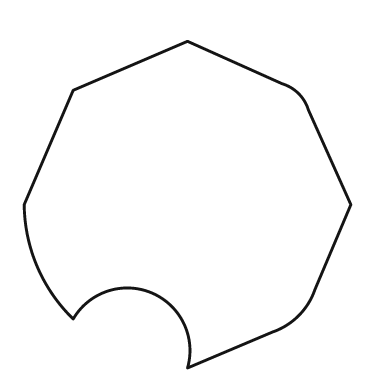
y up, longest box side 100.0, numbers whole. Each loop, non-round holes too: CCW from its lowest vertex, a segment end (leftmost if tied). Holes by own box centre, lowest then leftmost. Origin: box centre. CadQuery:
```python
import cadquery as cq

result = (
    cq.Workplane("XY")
    .moveTo(0.0, -50.0)
    .lineTo(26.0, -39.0)
    .threePointArc((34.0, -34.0), (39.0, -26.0))
    .lineTo(50.0, 0.0)
    .lineTo(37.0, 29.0)
    .threePointArc((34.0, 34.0), (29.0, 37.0))
    .lineTo(0.0, 50.0)
    .lineTo(-35.0, 35.0)
    .lineTo(-50.0, 0.0)
    .threePointArc((-46.0, -19.0), (-35.0, -35.0))
    .threePointArc((-11.0, -27.0), (0.0, -50.0))
    .close()
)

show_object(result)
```